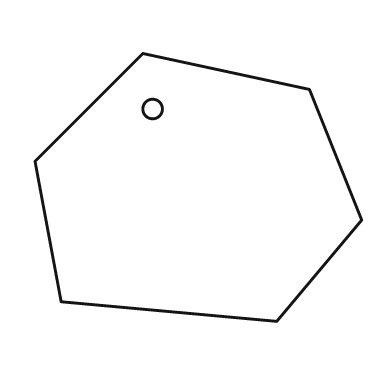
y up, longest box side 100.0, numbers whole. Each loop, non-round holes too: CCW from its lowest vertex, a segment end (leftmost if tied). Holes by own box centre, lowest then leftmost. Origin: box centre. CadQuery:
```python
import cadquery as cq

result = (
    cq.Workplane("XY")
    .moveTo(24.0, -41.0)
    .lineTo(50.0, -10.0)
    .lineTo(34.0, 30.0)
    .lineTo(-17.0, 41.0)
    .lineTo(-50.0, 8.0)
    .lineTo(-42.0, -35.0)
    .close()
    .moveTo(-14.0, 24.0)
    .circle(3.0)
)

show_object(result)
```